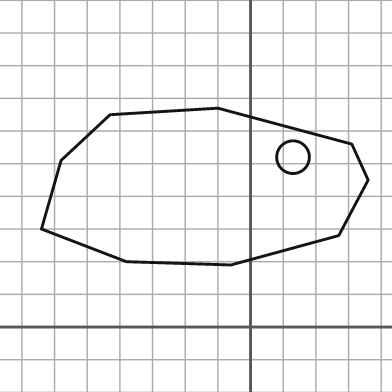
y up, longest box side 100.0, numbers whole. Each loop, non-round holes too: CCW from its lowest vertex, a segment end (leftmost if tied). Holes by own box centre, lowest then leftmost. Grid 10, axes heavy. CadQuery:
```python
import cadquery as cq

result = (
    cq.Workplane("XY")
    .moveTo(-6.0, 19.0)
    .lineTo(27.0, 28.0)
    .lineTo(36.0, 45.0)
    .lineTo(31.0, 56.0)
    .lineTo(-10.0, 67.0)
    .lineTo(-43.0, 65.0)
    .lineTo(-58.0, 51.0)
    .lineTo(-64.0, 30.0)
    .lineTo(-38.0, 20.0)
    .close()
    .moveTo(13.0, 52.0)
    .circle(5.0)
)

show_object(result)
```